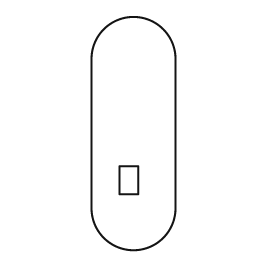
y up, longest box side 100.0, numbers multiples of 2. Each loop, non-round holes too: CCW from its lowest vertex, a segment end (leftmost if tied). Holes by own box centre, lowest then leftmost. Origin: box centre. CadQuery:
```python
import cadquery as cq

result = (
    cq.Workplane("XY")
    .moveTo(-18.0, -32.0)
    .threePointArc((0.0, -50.0), (18.0, -32.0))
    .lineTo(18.0, 32.0)
    .threePointArc((0.0, 50.0), (-18.0, 32.0))
    .close()
    .moveTo(-6.0, -26.0)
    .lineTo(2.0, -26.0)
    .lineTo(2.0, -14.0)
    .lineTo(-6.0, -14.0)
    .close()
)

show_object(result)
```